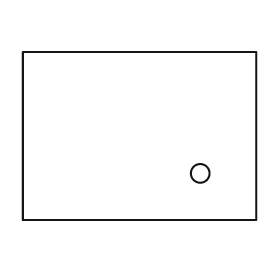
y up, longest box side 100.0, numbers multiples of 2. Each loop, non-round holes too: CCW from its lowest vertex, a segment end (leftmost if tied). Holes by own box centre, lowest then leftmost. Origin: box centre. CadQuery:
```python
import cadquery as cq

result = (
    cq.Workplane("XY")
    .moveTo(-50.0, -36.0)
    .lineTo(50.0, -36.0)
    .lineTo(50.0, 36.0)
    .lineTo(-50.0, 36.0)
    .close()
    .moveTo(26.0, -16.0)
    .circle(4.0)
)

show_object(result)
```